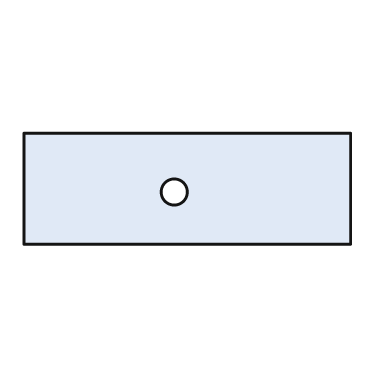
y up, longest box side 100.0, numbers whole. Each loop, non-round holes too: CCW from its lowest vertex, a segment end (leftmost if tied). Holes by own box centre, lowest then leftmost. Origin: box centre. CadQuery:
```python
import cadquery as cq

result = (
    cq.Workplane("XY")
    .moveTo(-50.0, -17.0)
    .lineTo(50.0, -17.0)
    .lineTo(50.0, 17.0)
    .lineTo(-50.0, 17.0)
    .close()
    .moveTo(-4.0, -1.0)
    .circle(4.0)
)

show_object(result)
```